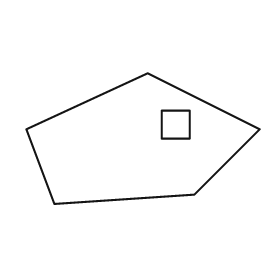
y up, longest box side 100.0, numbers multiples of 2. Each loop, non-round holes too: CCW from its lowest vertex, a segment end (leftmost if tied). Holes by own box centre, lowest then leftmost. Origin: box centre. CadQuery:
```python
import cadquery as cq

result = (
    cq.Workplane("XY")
    .moveTo(-38.0, -28.0)
    .lineTo(22.0, -24.0)
    .lineTo(50.0, 4.0)
    .lineTo(2.0, 28.0)
    .lineTo(-50.0, 4.0)
    .close()
    .moveTo(8.0, 0.0)
    .lineTo(20.0, 0.0)
    .lineTo(20.0, 12.0)
    .lineTo(8.0, 12.0)
    .close()
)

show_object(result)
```